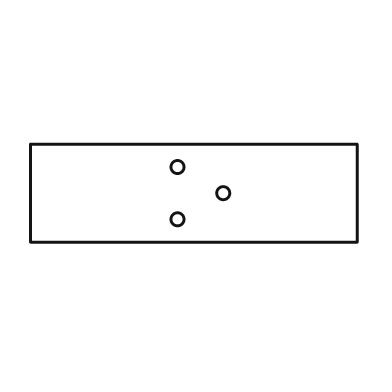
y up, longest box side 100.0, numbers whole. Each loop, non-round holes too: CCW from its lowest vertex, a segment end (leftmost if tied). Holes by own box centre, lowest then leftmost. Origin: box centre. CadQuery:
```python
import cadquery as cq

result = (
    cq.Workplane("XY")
    .moveTo(-50.0, -15.0)
    .lineTo(50.0, -15.0)
    .lineTo(50.0, 15.0)
    .lineTo(-50.0, 15.0)
    .close()
    .moveTo(-5.0, -8.0)
    .circle(2.0)
    .moveTo(9.0, 0.0)
    .circle(2.0)
    .moveTo(-5.0, 8.0)
    .circle(2.0)
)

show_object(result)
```